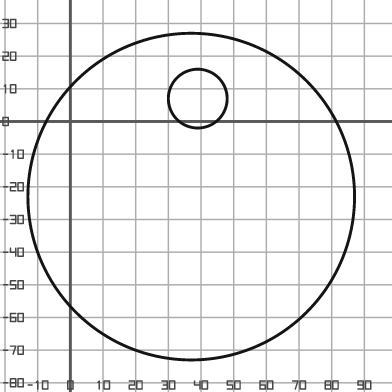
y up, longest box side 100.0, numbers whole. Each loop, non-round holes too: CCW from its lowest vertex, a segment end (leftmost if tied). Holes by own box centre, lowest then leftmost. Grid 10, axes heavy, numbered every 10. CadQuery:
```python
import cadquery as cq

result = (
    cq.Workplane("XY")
    .moveTo(37.0, -23.0)
    .circle(50.0)
    .moveTo(39.0, 7.0)
    .circle(9.0)
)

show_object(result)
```